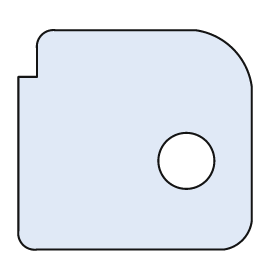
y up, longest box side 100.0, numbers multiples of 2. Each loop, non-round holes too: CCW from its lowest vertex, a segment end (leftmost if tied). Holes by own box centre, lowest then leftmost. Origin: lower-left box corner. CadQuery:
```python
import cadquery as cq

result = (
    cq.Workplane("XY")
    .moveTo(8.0, 0.0)
    .lineTo(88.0, 0.0)
    .threePointArc((96.0, 4.0), (100.0, 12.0))
    .lineTo(100.0, 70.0)
    .threePointArc((92.0, 86.0), (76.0, 94.0))
    .lineTo(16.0, 94.0)
    .threePointArc((10.0, 92.0), (8.0, 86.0))
    .lineTo(8.0, 74.0)
    .lineTo(0.0, 74.0)
    .lineTo(0.0, 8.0)
    .threePointArc((2.0, 2.0), (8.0, 0.0))
    .close()
    .moveTo(72.0, 38.0)
    .circle(12.0)
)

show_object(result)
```